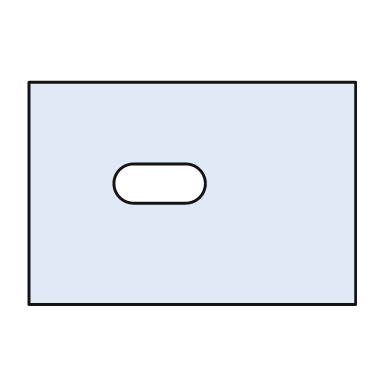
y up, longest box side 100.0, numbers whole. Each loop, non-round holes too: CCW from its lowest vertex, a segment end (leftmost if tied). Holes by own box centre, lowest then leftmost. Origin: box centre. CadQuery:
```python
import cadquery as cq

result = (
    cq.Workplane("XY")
    .moveTo(-50.0, -34.0)
    .lineTo(50.0, -34.0)
    .lineTo(50.0, 34.0)
    .lineTo(-50.0, 34.0)
    .close()
    .moveTo(-18.0, -3.0)
    .lineTo(-2.0, -3.0)
    .threePointArc((4.0, 3.0), (-2.0, 9.0))
    .lineTo(-18.0, 9.0)
    .threePointArc((-24.0, 3.0), (-18.0, -3.0))
    .close()
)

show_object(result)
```